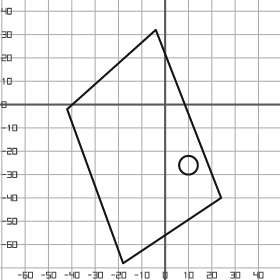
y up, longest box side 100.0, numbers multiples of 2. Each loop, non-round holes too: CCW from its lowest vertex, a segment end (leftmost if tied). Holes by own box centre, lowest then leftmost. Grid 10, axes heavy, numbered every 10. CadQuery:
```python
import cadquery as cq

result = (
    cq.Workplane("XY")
    .moveTo(-18.0, -68.0)
    .lineTo(24.0, -40.0)
    .lineTo(-4.0, 32.0)
    .lineTo(-42.0, -2.0)
    .close()
    .moveTo(10.0, -26.0)
    .circle(4.0)
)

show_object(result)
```